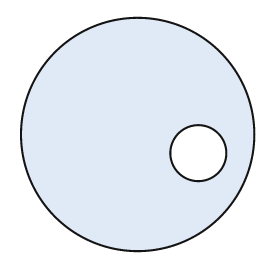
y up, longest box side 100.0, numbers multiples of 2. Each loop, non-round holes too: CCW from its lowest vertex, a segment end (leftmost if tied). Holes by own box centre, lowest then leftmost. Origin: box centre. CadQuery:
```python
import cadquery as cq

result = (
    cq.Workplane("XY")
    .moveTo(0.0, 0.0)
    .circle(50.0)
    .moveTo(26.0, -8.0)
    .circle(12.0)
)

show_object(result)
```